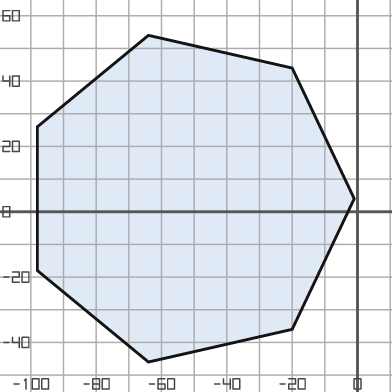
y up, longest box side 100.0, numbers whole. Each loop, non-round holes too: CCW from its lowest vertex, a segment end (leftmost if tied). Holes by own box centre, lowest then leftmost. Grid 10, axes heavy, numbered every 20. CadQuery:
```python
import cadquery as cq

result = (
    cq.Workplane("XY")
    .moveTo(-64.0, -46.0)
    .lineTo(-20.0, -36.0)
    .lineTo(-1.0, 4.0)
    .lineTo(-20.0, 44.0)
    .lineTo(-64.0, 54.0)
    .lineTo(-98.0, 26.0)
    .lineTo(-98.0, -18.0)
    .close()
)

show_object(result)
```